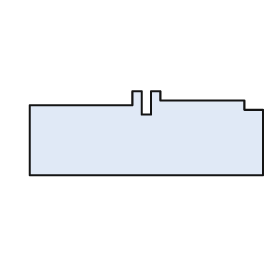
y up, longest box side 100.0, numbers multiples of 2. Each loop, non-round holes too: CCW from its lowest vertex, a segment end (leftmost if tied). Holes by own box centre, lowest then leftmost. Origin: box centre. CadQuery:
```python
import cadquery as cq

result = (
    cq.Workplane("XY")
    .moveTo(-50.0, -18.0)
    .lineTo(50.0, -18.0)
    .lineTo(50.0, 10.0)
    .lineTo(42.0, 10.0)
    .lineTo(42.0, 14.0)
    .lineTo(6.0, 14.0)
    .lineTo(6.0, 18.0)
    .lineTo(2.0, 18.0)
    .lineTo(2.0, 8.0)
    .lineTo(-2.0, 8.0)
    .lineTo(-2.0, 18.0)
    .lineTo(-6.0, 18.0)
    .lineTo(-6.0, 12.0)
    .lineTo(-50.0, 12.0)
    .close()
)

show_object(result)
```